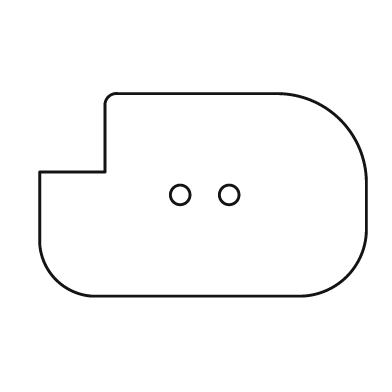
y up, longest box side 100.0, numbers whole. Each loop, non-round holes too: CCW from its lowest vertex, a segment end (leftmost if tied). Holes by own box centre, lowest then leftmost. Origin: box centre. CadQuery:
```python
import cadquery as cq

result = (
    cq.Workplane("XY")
    .moveTo(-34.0, -31.0)
    .lineTo(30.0, -31.0)
    .threePointArc((44.0, -25.0), (50.0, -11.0))
    .lineTo(50.0, 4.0)
    .threePointArc((42.0, 23.0), (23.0, 31.0))
    .lineTo(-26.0, 31.0)
    .threePointArc((-29.0, 30.0), (-30.0, 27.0))
    .lineTo(-30.0, 7.0)
    .lineTo(-50.0, 7.0)
    .lineTo(-50.0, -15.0)
    .threePointArc((-45.0, -26.0), (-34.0, -31.0))
    .close()
    .moveTo(-7.0, 0.0)
    .circle(3.0)
    .moveTo(8.0, 0.0)
    .circle(3.0)
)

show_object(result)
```